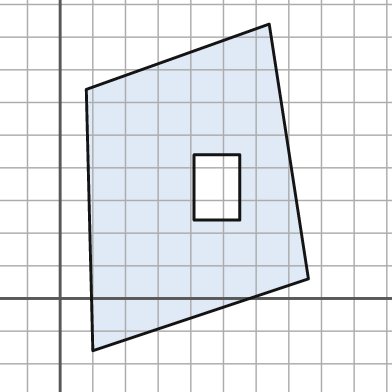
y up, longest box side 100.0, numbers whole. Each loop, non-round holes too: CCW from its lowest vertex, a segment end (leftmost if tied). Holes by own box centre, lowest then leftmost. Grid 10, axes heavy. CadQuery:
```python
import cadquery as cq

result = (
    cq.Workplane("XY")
    .moveTo(10.0, -16.0)
    .lineTo(76.0, 6.0)
    .lineTo(64.0, 84.0)
    .lineTo(8.0, 64.0)
    .close()
    .moveTo(41.0, 24.0)
    .lineTo(55.0, 24.0)
    .lineTo(55.0, 44.0)
    .lineTo(41.0, 44.0)
    .close()
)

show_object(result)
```